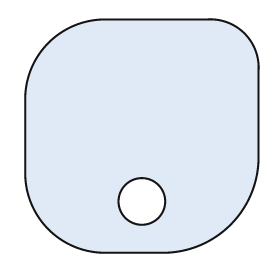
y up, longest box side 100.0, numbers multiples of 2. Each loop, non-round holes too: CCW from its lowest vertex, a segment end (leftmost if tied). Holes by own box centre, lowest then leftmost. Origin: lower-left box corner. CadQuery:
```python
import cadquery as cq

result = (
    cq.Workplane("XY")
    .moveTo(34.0, 0.0)
    .lineTo(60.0, 0.0)
    .threePointArc((88.0, 12.0), (100.0, 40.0))
    .lineTo(100.0, 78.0)
    .threePointArc((94.0, 94.0), (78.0, 100.0))
    .lineTo(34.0, 100.0)
    .threePointArc((10.0, 90.0), (0.0, 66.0))
    .lineTo(0.0, 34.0)
    .threePointArc((10.0, 10.0), (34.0, 0.0))
    .close()
    .moveTo(50.0, 22.0)
    .circle(10.0)
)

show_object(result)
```